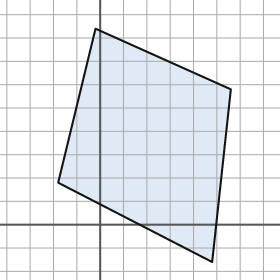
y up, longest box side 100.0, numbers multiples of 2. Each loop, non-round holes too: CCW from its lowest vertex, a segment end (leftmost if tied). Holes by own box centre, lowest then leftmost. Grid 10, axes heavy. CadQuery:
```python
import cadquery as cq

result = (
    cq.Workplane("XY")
    .moveTo(48.0, -16.0)
    .lineTo(56.0, 58.0)
    .lineTo(-2.0, 84.0)
    .lineTo(-18.0, 18.0)
    .close()
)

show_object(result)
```